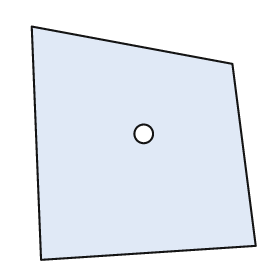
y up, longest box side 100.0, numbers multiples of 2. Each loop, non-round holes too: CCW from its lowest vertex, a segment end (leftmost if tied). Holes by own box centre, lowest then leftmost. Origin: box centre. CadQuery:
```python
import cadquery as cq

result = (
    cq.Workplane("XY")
    .moveTo(-44.0, -50.0)
    .lineTo(48.0, -44.0)
    .lineTo(38.0, 34.0)
    .lineTo(-48.0, 50.0)
    .close()
    .moveTo(0.0, 4.0)
    .circle(4.0)
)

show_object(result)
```